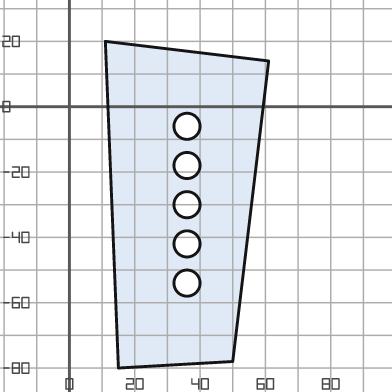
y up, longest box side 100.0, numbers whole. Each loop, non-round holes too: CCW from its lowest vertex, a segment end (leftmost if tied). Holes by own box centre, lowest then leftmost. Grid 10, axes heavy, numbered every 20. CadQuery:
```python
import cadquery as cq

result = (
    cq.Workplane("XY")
    .moveTo(15.0, -80.0)
    .lineTo(50.0, -78.0)
    .lineTo(61.0, 14.0)
    .lineTo(11.0, 20.0)
    .close()
    .moveTo(36.0, -54.0)
    .circle(4.0)
    .moveTo(36.0, -42.0)
    .circle(4.0)
    .moveTo(36.0, -30.0)
    .circle(4.0)
    .moveTo(36.0, -18.0)
    .circle(4.0)
    .moveTo(36.0, -6.0)
    .circle(4.0)
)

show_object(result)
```